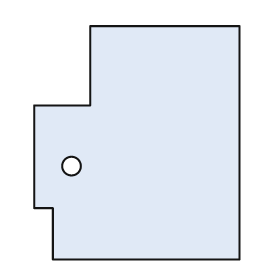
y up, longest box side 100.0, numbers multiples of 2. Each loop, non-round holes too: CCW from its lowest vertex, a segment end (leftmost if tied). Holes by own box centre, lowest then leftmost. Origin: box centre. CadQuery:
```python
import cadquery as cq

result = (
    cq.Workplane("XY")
    .moveTo(-36.0, -50.0)
    .lineTo(44.0, -50.0)
    .lineTo(44.0, 50.0)
    .lineTo(-20.0, 50.0)
    .lineTo(-20.0, 16.0)
    .lineTo(-44.0, 16.0)
    .lineTo(-44.0, -28.0)
    .lineTo(-36.0, -28.0)
    .close()
    .moveTo(-28.0, -10.0)
    .circle(4.0)
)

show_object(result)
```